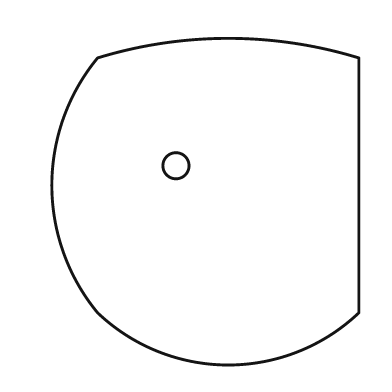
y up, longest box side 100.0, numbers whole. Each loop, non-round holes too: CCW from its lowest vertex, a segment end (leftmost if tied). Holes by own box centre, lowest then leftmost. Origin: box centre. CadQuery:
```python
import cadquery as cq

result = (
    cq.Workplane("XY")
    .moveTo(-33.0, -34.0)
    .threePointArc((7.0, -50.0), (47.0, -34.0))
    .lineTo(47.0, 44.0)
    .threePointArc((7.0, 50.0), (-33.0, 44.0))
    .threePointArc((-47.0, 5.0), (-33.0, -34.0))
    .close()
    .moveTo(-9.0, 11.0)
    .circle(4.0)
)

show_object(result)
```